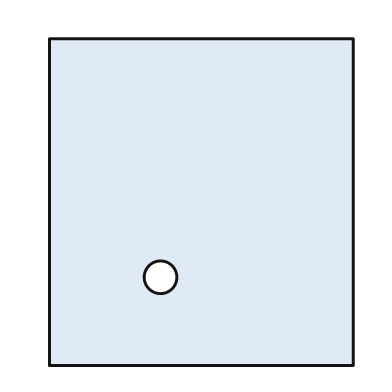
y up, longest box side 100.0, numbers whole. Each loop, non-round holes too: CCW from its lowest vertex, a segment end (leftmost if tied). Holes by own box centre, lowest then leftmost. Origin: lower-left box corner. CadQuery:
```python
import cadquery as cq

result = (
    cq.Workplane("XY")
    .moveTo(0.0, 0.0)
    .lineTo(93.0, 0.0)
    .lineTo(93.0, 100.0)
    .lineTo(0.0, 100.0)
    .close()
    .moveTo(34.0, 27.0)
    .circle(5.0)
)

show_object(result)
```